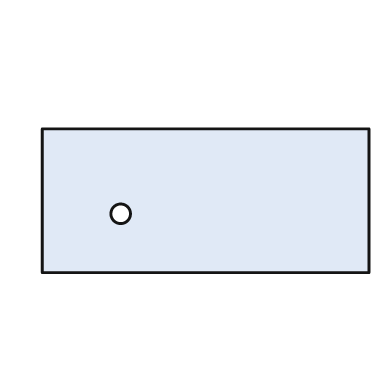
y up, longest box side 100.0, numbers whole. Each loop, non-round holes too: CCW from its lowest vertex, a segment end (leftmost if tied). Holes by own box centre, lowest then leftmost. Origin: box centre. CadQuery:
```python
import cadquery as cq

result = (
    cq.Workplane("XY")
    .moveTo(-50.0, -22.0)
    .lineTo(50.0, -22.0)
    .lineTo(50.0, 22.0)
    .lineTo(-50.0, 22.0)
    .close()
    .moveTo(-26.0, -4.0)
    .circle(3.0)
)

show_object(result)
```